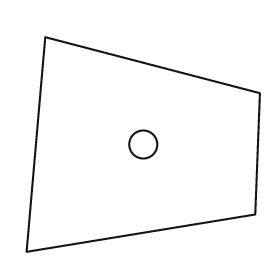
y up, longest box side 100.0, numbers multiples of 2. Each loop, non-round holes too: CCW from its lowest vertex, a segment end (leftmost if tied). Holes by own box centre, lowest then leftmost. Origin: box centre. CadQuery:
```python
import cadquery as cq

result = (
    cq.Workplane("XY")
    .moveTo(-50.0, -46.0)
    .lineTo(48.0, -30.0)
    .lineTo(50.0, 22.0)
    .lineTo(-42.0, 46.0)
    .close()
    .moveTo(0.0, 0.0)
    .circle(6.0)
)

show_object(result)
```